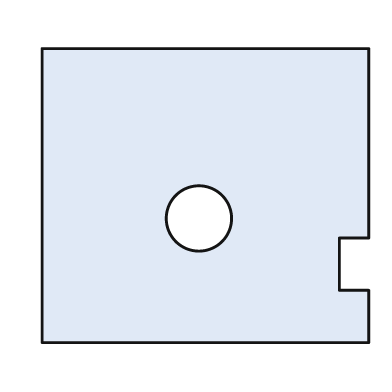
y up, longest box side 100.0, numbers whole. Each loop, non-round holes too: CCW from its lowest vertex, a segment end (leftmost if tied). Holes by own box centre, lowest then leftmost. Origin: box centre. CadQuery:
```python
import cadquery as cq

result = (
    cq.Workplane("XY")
    .moveTo(-50.0, -45.0)
    .lineTo(50.0, -45.0)
    .lineTo(50.0, -29.0)
    .lineTo(41.0, -29.0)
    .lineTo(41.0, -13.0)
    .lineTo(50.0, -13.0)
    .lineTo(50.0, 45.0)
    .lineTo(-50.0, 45.0)
    .close()
    .moveTo(-2.0, -7.0)
    .circle(10.0)
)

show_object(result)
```